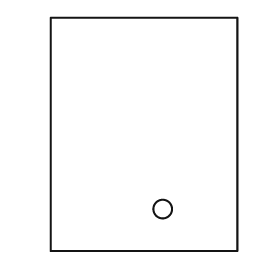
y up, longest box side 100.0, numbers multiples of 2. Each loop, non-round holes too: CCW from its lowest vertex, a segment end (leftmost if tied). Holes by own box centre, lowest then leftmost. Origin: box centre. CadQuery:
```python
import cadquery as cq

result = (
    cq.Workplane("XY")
    .moveTo(-40.0, -50.0)
    .lineTo(40.0, -50.0)
    .lineTo(40.0, 50.0)
    .lineTo(-40.0, 50.0)
    .close()
    .moveTo(8.0, -32.0)
    .circle(4.0)
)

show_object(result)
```